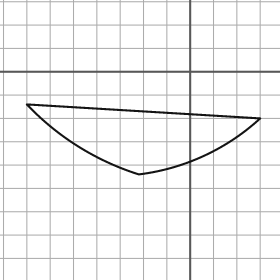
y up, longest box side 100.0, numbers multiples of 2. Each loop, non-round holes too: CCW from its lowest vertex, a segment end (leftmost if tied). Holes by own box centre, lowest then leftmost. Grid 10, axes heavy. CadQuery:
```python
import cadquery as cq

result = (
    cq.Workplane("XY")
    .moveTo(-22.0, -44.0)
    .threePointArc((6.0, -36.0), (30.0, -20.0))
    .lineTo(-70.0, -14.0)
    .threePointArc((-48.0, -32.0), (-22.0, -44.0))
    .close()
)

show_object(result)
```